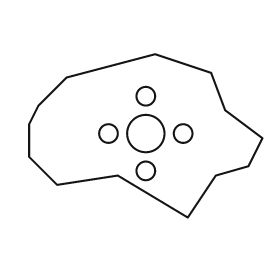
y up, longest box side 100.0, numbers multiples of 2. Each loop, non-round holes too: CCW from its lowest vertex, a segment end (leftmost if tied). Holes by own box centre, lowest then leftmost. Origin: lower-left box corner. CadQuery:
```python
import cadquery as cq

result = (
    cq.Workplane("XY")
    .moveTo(68.0, 0.0)
    .lineTo(80.0, 18.0)
    .lineTo(94.0, 22.0)
    .lineTo(100.0, 34.0)
    .lineTo(84.0, 46.0)
    .lineTo(78.0, 62.0)
    .lineTo(54.0, 70.0)
    .lineTo(16.0, 60.0)
    .lineTo(4.0, 48.0)
    .lineTo(0.0, 40.0)
    .lineTo(0.0, 26.0)
    .lineTo(12.0, 14.0)
    .lineTo(38.0, 18.0)
    .close()
    .moveTo(50.0, 20.0)
    .circle(4.0)
    .moveTo(34.0, 36.0)
    .circle(4.0)
    .moveTo(50.0, 36.0)
    .circle(8.0)
    .moveTo(66.0, 36.0)
    .circle(4.0)
    .moveTo(50.0, 52.0)
    .circle(4.0)
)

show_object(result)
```